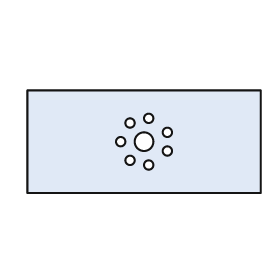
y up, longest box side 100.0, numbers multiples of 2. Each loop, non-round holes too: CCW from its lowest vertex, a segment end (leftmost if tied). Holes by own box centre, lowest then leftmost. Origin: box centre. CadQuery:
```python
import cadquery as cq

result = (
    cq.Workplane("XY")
    .moveTo(-50.0, -22.0)
    .lineTo(50.0, -22.0)
    .lineTo(50.0, 22.0)
    .lineTo(-50.0, 22.0)
    .close()
    .moveTo(2.0, -10.0)
    .circle(2.0)
    .moveTo(-6.0, -8.0)
    .circle(2.0)
    .moveTo(10.0, -4.0)
    .circle(2.0)
    .moveTo(-10.0, 0.0)
    .circle(2.0)
    .moveTo(0.0, 0.0)
    .circle(4.0)
    .moveTo(10.0, 4.0)
    .circle(2.0)
    .moveTo(-6.0, 8.0)
    .circle(2.0)
    .moveTo(2.0, 10.0)
    .circle(2.0)
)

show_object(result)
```